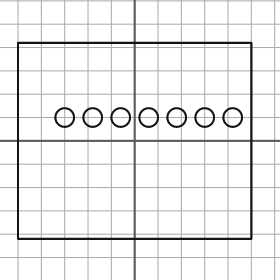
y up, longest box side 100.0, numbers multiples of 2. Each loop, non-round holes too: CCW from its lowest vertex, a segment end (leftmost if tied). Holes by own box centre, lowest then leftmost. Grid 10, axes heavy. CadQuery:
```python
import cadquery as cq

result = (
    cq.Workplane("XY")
    .moveTo(-50.0, -42.0)
    .lineTo(50.0, -42.0)
    .lineTo(50.0, 42.0)
    .lineTo(-50.0, 42.0)
    .close()
    .moveTo(-30.0, 10.0)
    .circle(4.0)
    .moveTo(-18.0, 10.0)
    .circle(4.0)
    .moveTo(-6.0, 10.0)
    .circle(4.0)
    .moveTo(6.0, 10.0)
    .circle(4.0)
    .moveTo(18.0, 10.0)
    .circle(4.0)
    .moveTo(30.0, 10.0)
    .circle(4.0)
    .moveTo(42.0, 10.0)
    .circle(4.0)
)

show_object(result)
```